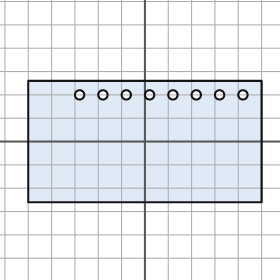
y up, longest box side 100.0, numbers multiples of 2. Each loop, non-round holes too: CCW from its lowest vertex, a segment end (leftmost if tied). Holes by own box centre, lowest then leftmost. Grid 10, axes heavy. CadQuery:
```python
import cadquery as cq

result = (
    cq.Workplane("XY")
    .moveTo(-50.0, -26.0)
    .lineTo(50.0, -26.0)
    .lineTo(50.0, 26.0)
    .lineTo(-50.0, 26.0)
    .close()
    .moveTo(-28.0, 20.0)
    .circle(2.0)
    .moveTo(-18.0, 20.0)
    .circle(2.0)
    .moveTo(-8.0, 20.0)
    .circle(2.0)
    .moveTo(2.0, 20.0)
    .circle(2.0)
    .moveTo(12.0, 20.0)
    .circle(2.0)
    .moveTo(22.0, 20.0)
    .circle(2.0)
    .moveTo(32.0, 20.0)
    .circle(2.0)
    .moveTo(42.0, 20.0)
    .circle(2.0)
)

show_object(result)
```